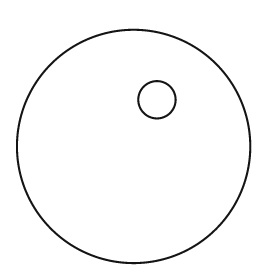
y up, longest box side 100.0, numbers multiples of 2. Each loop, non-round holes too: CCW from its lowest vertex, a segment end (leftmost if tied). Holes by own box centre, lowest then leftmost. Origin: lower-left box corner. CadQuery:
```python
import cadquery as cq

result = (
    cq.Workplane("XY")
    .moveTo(50.0, 50.0)
    .circle(50.0)
    .moveTo(60.0, 70.0)
    .circle(8.0)
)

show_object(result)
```